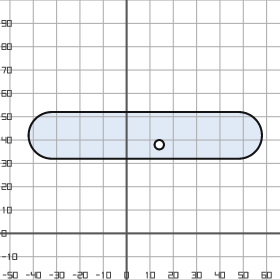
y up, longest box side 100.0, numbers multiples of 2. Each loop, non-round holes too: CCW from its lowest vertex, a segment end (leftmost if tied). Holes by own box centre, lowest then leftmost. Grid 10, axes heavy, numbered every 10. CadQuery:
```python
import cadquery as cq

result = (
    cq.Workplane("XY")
    .moveTo(-32.0, 32.0)
    .lineTo(48.0, 32.0)
    .threePointArc((58.0, 42.0), (48.0, 52.0))
    .lineTo(-32.0, 52.0)
    .threePointArc((-42.0, 42.0), (-32.0, 32.0))
    .close()
    .moveTo(14.0, 38.0)
    .circle(2.0)
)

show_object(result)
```